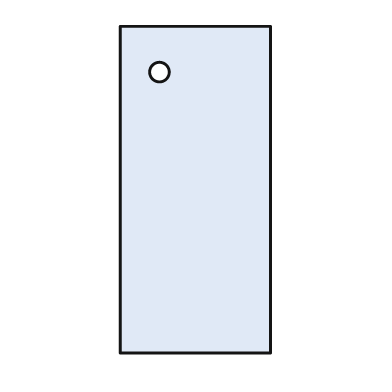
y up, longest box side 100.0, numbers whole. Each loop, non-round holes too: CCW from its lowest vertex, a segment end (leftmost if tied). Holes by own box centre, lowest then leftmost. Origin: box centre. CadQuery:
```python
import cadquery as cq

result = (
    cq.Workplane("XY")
    .moveTo(-23.0, -50.0)
    .lineTo(23.0, -50.0)
    .lineTo(23.0, 50.0)
    .lineTo(-23.0, 50.0)
    .close()
    .moveTo(-11.0, 36.0)
    .circle(3.0)
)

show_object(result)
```